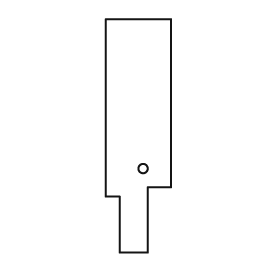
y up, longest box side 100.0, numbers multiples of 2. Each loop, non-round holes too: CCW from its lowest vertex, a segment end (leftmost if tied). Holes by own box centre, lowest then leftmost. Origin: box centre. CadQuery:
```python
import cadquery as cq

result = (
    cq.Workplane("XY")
    .moveTo(-8.0, -50.0)
    .lineTo(4.0, -50.0)
    .lineTo(4.0, -22.0)
    .lineTo(14.0, -22.0)
    .lineTo(14.0, 50.0)
    .lineTo(-14.0, 50.0)
    .lineTo(-14.0, -26.0)
    .lineTo(-8.0, -26.0)
    .close()
    .moveTo(2.0, -14.0)
    .circle(2.0)
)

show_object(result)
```